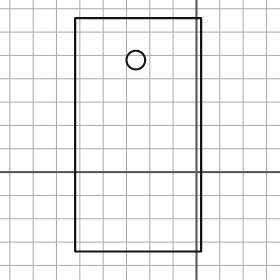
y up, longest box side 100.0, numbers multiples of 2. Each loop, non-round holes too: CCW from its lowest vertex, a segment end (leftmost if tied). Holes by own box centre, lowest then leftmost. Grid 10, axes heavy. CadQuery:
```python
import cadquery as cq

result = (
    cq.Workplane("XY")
    .moveTo(-52.0, -34.0)
    .lineTo(2.0, -34.0)
    .lineTo(2.0, 66.0)
    .lineTo(-52.0, 66.0)
    .close()
    .moveTo(-26.0, 48.0)
    .circle(4.0)
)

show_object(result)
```